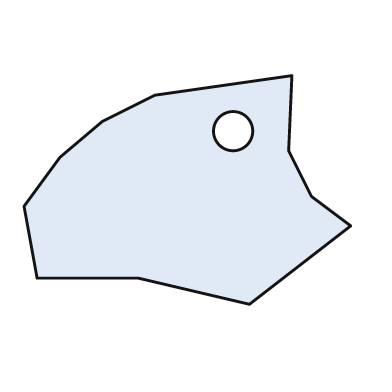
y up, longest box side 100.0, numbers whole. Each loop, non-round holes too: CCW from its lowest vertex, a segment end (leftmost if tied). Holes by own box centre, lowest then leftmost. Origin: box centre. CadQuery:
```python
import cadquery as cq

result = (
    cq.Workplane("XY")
    .moveTo(19.0, -35.0)
    .lineTo(50.0, -11.0)
    .lineTo(38.0, -2.0)
    .lineTo(31.0, 12.0)
    .lineTo(32.0, 35.0)
    .lineTo(-10.0, 29.0)
    .lineTo(-26.0, 21.0)
    .lineTo(-39.0, 10.0)
    .lineTo(-50.0, -5.0)
    .lineTo(-46.0, -27.0)
    .lineTo(-15.0, -27.0)
    .close()
    .moveTo(14.0, 18.0)
    .circle(6.0)
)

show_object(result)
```